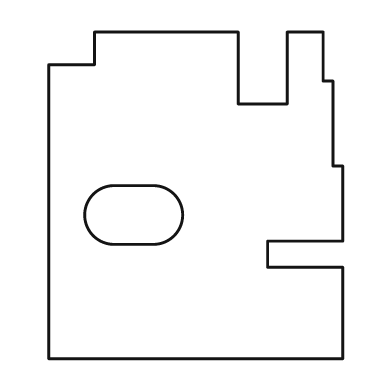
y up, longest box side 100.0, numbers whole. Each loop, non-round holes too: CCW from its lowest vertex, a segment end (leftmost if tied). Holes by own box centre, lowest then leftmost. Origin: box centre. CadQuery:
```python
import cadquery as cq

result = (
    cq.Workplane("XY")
    .moveTo(-45.0, -50.0)
    .lineTo(45.0, -50.0)
    .lineTo(45.0, -22.0)
    .lineTo(22.0, -22.0)
    .lineTo(22.0, -14.0)
    .lineTo(45.0, -14.0)
    .lineTo(45.0, 9.0)
    .lineTo(42.0, 9.0)
    .lineTo(42.0, 35.0)
    .lineTo(39.0, 35.0)
    .lineTo(39.0, 50.0)
    .lineTo(28.0, 50.0)
    .lineTo(28.0, 28.0)
    .lineTo(13.0, 28.0)
    .lineTo(13.0, 50.0)
    .lineTo(-31.0, 50.0)
    .lineTo(-31.0, 40.0)
    .lineTo(-45.0, 40.0)
    .close()
    .moveTo(-25.0, -15.0)
    .lineTo(-13.0, -15.0)
    .threePointArc((-4.0, -6.0), (-13.0, 3.0))
    .lineTo(-25.0, 3.0)
    .threePointArc((-34.0, -6.0), (-25.0, -15.0))
    .close()
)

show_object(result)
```